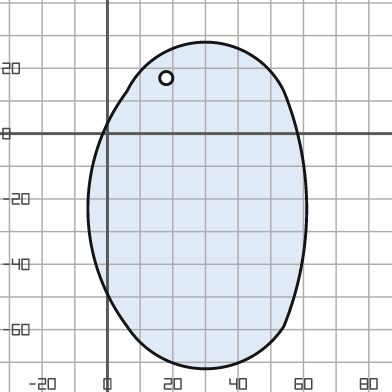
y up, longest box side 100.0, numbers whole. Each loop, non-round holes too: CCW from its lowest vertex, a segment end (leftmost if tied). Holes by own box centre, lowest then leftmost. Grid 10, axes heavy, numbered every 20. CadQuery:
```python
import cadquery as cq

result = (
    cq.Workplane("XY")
    .moveTo(6.0, -59.0)
    .threePointArc((30.0, -72.0), (54.0, -59.0))
    .threePointArc((61.0, -23.0), (54.0, 13.0))
    .threePointArc((30.0, 28.0), (6.0, 13.0))
    .threePointArc((-6.0, -23.0), (6.0, -59.0))
    .close()
    .moveTo(18.0, 17.0)
    .circle(2.0)
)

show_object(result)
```